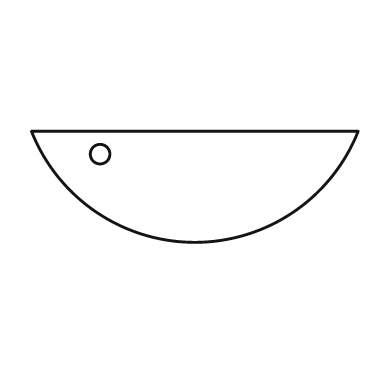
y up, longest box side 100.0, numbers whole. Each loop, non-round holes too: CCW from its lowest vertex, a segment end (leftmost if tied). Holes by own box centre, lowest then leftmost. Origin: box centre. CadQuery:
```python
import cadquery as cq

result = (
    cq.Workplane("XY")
    .moveTo(-50.0, 17.0)
    .threePointArc((0.0, -17.0), (50.0, 17.0))
    .close()
    .moveTo(-29.0, 10.0)
    .circle(3.0)
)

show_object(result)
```